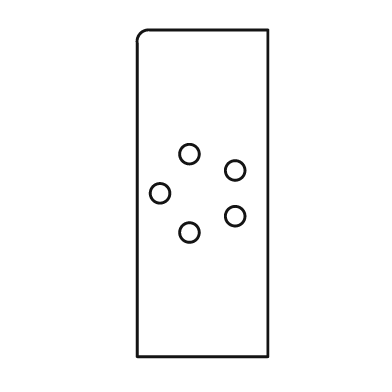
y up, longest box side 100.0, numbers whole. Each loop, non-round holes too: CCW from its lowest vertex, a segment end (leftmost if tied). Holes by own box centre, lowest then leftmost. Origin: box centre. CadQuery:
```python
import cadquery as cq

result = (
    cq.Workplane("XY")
    .moveTo(-20.0, -50.0)
    .lineTo(20.0, -50.0)
    .lineTo(20.0, 50.0)
    .lineTo(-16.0, 50.0)
    .threePointArc((-19.0, 49.0), (-20.0, 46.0))
    .close()
    .moveTo(-4.0, -12.0)
    .circle(3.0)
    .moveTo(10.0, -7.0)
    .circle(3.0)
    .moveTo(-13.0, 0.0)
    .circle(3.0)
    .moveTo(10.0, 7.0)
    .circle(3.0)
    .moveTo(-4.0, 12.0)
    .circle(3.0)
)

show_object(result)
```